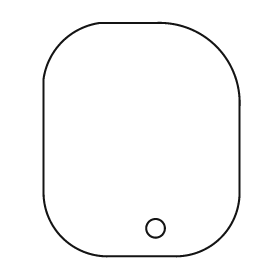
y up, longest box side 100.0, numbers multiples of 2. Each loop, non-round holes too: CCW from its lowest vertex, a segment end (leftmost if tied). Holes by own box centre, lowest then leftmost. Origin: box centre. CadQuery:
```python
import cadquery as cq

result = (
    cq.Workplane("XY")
    .moveTo(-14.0, -50.0)
    .lineTo(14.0, -50.0)
    .threePointArc((34.0, -42.0), (42.0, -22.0))
    .lineTo(42.0, 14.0)
    .threePointArc((32.0, 40.0), (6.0, 50.0))
    .lineTo(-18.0, 50.0)
    .threePointArc((-34.0, 42.0), (-42.0, 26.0))
    .lineTo(-42.0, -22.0)
    .threePointArc((-34.0, -42.0), (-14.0, -50.0))
    .close()
    .moveTo(6.0, -38.0)
    .circle(4.0)
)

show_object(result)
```